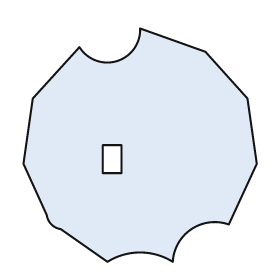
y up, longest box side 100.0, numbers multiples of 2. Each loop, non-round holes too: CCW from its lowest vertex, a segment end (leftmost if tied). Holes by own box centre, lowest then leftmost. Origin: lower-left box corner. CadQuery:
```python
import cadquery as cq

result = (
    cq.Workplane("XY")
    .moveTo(36.0, 0.0)
    .threePointArc((50.0, 4.0), (64.0, 0.0))
    .threePointArc((72.0, 14.0), (88.0, 16.0))
    .lineTo(100.0, 42.0)
    .lineTo(96.0, 70.0)
    .lineTo(78.0, 90.0)
    .lineTo(50.0, 100.0)
    .threePointArc((40.0, 86.0), (24.0, 92.0))
    .lineTo(4.0, 70.0)
    .lineTo(0.0, 42.0)
    .lineTo(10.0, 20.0)
    .threePointArc((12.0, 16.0), (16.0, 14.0))
    .close()
    .moveTo(34.0, 38.0)
    .lineTo(42.0, 38.0)
    .lineTo(42.0, 50.0)
    .lineTo(34.0, 50.0)
    .close()
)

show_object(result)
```